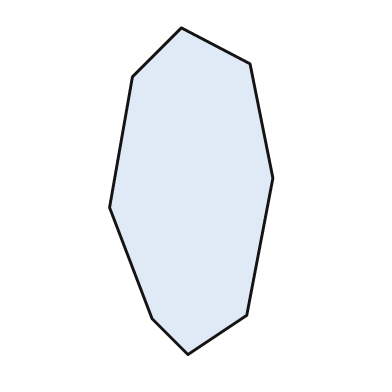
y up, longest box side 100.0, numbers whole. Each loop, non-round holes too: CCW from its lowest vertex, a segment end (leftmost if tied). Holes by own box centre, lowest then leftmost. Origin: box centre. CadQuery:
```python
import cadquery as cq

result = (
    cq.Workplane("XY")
    .moveTo(-1.0, -50.0)
    .lineTo(17.0, -38.0)
    .lineTo(25.0, 4.0)
    .lineTo(18.0, 39.0)
    .lineTo(-3.0, 50.0)
    .lineTo(-18.0, 35.0)
    .lineTo(-25.0, -5.0)
    .lineTo(-12.0, -39.0)
    .close()
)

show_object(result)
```